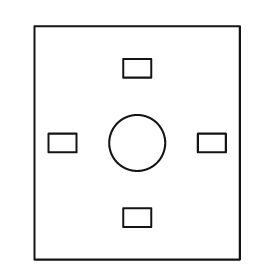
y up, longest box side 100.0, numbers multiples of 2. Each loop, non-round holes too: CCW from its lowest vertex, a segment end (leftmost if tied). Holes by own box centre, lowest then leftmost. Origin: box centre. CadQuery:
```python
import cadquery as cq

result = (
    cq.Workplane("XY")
    .moveTo(-44.0, -50.0)
    .lineTo(44.0, -50.0)
    .lineTo(44.0, 50.0)
    .lineTo(-44.0, 50.0)
    .close()
    .moveTo(-6.0, -36.0)
    .lineTo(6.0, -36.0)
    .lineTo(6.0, -28.0)
    .lineTo(-6.0, -28.0)
    .close()
    .moveTo(-38.0, -4.0)
    .lineTo(-26.0, -4.0)
    .lineTo(-26.0, 4.0)
    .lineTo(-38.0, 4.0)
    .close()
    .moveTo(0.0, 0.0)
    .circle(12.0)
    .moveTo(26.0, -4.0)
    .lineTo(38.0, -4.0)
    .lineTo(38.0, 4.0)
    .lineTo(26.0, 4.0)
    .close()
    .moveTo(-6.0, 28.0)
    .lineTo(6.0, 28.0)
    .lineTo(6.0, 36.0)
    .lineTo(-6.0, 36.0)
    .close()
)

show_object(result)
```